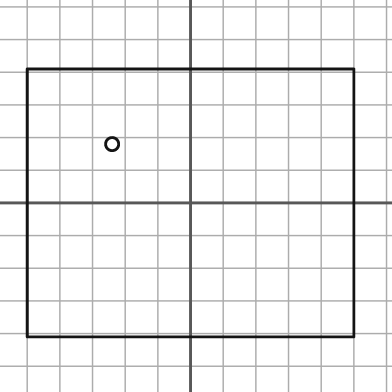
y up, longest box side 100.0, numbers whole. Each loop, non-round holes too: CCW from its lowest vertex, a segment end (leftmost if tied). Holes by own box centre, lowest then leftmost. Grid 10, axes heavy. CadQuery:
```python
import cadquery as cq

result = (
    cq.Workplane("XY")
    .moveTo(-50.0, -41.0)
    .lineTo(50.0, -41.0)
    .lineTo(50.0, 41.0)
    .lineTo(-50.0, 41.0)
    .close()
    .moveTo(-24.0, 18.0)
    .circle(2.0)
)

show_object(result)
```